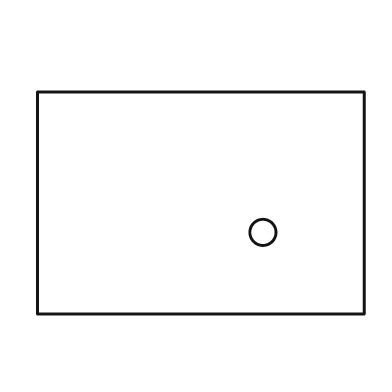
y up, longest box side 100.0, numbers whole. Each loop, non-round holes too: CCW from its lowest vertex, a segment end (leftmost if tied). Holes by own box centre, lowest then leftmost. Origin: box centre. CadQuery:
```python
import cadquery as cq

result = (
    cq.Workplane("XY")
    .moveTo(-50.0, -34.0)
    .lineTo(50.0, -34.0)
    .lineTo(50.0, 34.0)
    .lineTo(-50.0, 34.0)
    .close()
    .moveTo(19.0, -9.0)
    .circle(4.0)
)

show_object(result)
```